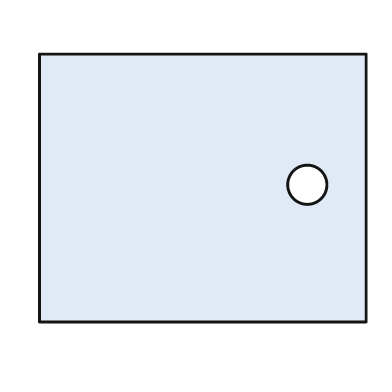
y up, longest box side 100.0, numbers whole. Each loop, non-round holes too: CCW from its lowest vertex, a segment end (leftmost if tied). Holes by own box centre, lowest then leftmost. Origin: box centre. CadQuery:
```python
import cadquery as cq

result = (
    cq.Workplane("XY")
    .moveTo(-50.0, -41.0)
    .lineTo(50.0, -41.0)
    .lineTo(50.0, 41.0)
    .lineTo(-50.0, 41.0)
    .close()
    .moveTo(32.0, 1.0)
    .circle(6.0)
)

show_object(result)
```